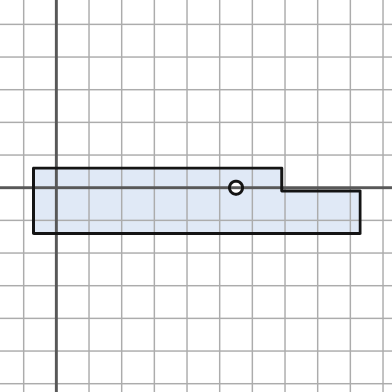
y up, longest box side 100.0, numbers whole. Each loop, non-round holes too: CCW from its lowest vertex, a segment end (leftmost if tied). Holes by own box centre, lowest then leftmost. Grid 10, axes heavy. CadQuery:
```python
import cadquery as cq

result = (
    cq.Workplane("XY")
    .moveTo(-7.0, -14.0)
    .lineTo(93.0, -14.0)
    .lineTo(93.0, -1.0)
    .lineTo(69.0, -1.0)
    .lineTo(69.0, 6.0)
    .lineTo(-7.0, 6.0)
    .close()
    .moveTo(55.0, 0.0)
    .circle(2.0)
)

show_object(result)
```